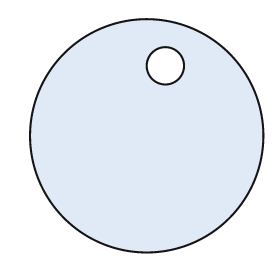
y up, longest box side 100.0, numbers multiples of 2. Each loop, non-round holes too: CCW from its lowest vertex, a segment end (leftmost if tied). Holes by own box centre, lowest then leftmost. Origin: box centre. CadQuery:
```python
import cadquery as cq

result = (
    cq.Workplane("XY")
    .moveTo(0.0, 0.0)
    .circle(50.0)
    .moveTo(8.0, 30.0)
    .circle(8.0)
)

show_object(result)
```